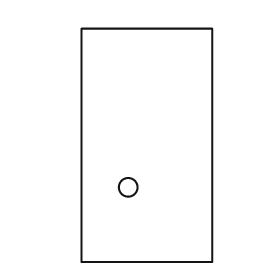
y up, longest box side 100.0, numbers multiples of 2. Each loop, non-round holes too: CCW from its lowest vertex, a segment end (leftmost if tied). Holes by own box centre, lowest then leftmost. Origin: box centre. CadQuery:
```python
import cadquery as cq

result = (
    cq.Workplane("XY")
    .moveTo(-28.0, -50.0)
    .lineTo(28.0, -50.0)
    .lineTo(28.0, 50.0)
    .lineTo(-28.0, 50.0)
    .close()
    .moveTo(-8.0, -18.0)
    .circle(4.0)
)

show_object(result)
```